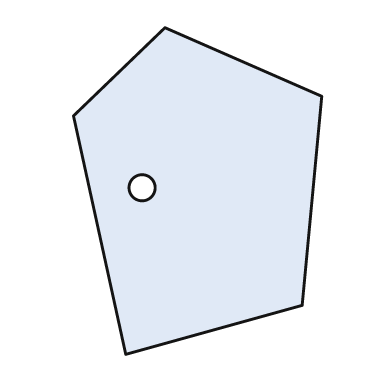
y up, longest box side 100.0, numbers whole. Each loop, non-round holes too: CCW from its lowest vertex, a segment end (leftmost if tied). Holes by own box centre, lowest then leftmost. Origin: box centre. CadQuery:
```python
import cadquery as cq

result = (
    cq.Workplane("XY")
    .moveTo(-22.0, -50.0)
    .lineTo(32.0, -35.0)
    .lineTo(38.0, 29.0)
    .lineTo(-10.0, 50.0)
    .lineTo(-38.0, 23.0)
    .close()
    .moveTo(-17.0, 1.0)
    .circle(4.0)
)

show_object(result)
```